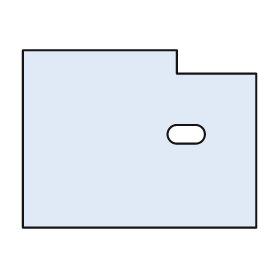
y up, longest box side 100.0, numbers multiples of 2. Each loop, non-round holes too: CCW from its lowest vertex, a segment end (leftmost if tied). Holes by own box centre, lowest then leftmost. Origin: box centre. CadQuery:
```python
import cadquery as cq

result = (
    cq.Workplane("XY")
    .moveTo(-50.0, -38.0)
    .lineTo(50.0, -38.0)
    .lineTo(50.0, 28.0)
    .lineTo(16.0, 28.0)
    .lineTo(16.0, 38.0)
    .lineTo(-50.0, 38.0)
    .close()
    .moveTo(16.0, -2.0)
    .lineTo(24.0, -2.0)
    .threePointArc((28.0, 2.0), (24.0, 6.0))
    .lineTo(16.0, 6.0)
    .threePointArc((12.0, 2.0), (16.0, -2.0))
    .close()
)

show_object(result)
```